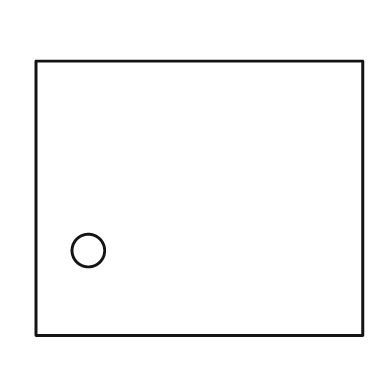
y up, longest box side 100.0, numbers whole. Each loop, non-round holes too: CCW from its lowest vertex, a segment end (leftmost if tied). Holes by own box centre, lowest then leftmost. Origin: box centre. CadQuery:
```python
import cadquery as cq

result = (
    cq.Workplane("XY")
    .moveTo(-50.0, -42.0)
    .lineTo(50.0, -42.0)
    .lineTo(50.0, 42.0)
    .lineTo(-50.0, 42.0)
    .close()
    .moveTo(-34.0, -16.0)
    .circle(5.0)
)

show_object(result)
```